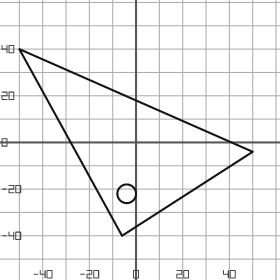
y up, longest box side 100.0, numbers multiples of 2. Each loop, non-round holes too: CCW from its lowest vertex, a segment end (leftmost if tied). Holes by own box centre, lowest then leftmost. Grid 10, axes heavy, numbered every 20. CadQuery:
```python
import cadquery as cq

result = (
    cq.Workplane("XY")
    .moveTo(-6.0, -40.0)
    .lineTo(50.0, -4.0)
    .lineTo(-50.0, 40.0)
    .close()
    .moveTo(-4.0, -22.0)
    .circle(4.0)
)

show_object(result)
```